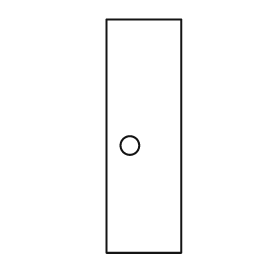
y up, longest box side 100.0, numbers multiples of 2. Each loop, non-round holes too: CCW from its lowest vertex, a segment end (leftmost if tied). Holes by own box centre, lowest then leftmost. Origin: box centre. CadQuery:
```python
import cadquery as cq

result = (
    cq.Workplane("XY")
    .moveTo(-16.0, -50.0)
    .lineTo(16.0, -50.0)
    .lineTo(16.0, 50.0)
    .lineTo(-16.0, 50.0)
    .close()
    .moveTo(-6.0, -4.0)
    .circle(4.0)
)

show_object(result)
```